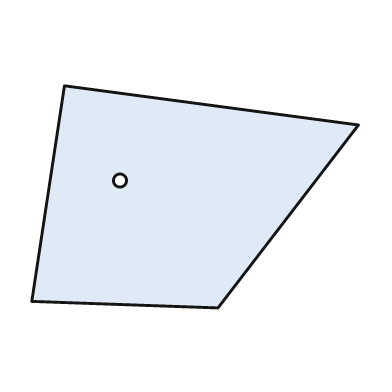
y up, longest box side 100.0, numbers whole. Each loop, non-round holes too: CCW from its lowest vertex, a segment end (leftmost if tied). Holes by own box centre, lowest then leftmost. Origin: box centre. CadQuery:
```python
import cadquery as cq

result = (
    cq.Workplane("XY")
    .moveTo(7.0, -34.0)
    .lineTo(50.0, 22.0)
    .lineTo(-40.0, 34.0)
    .lineTo(-50.0, -32.0)
    .close()
    .moveTo(-23.0, 5.0)
    .circle(2.0)
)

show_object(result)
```